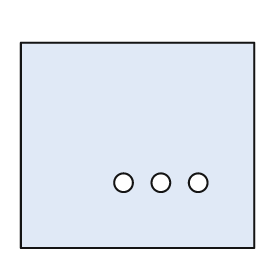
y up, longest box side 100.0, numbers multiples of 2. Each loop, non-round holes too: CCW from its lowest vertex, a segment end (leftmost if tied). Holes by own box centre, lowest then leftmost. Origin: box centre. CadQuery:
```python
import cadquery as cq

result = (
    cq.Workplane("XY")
    .moveTo(-50.0, -44.0)
    .lineTo(50.0, -44.0)
    .lineTo(50.0, 44.0)
    .lineTo(-50.0, 44.0)
    .close()
    .moveTo(-6.0, -16.0)
    .circle(4.0)
    .moveTo(10.0, -16.0)
    .circle(4.0)
    .moveTo(26.0, -16.0)
    .circle(4.0)
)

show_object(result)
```